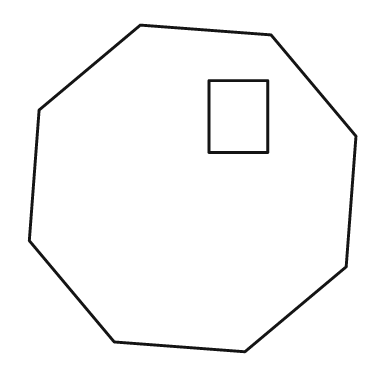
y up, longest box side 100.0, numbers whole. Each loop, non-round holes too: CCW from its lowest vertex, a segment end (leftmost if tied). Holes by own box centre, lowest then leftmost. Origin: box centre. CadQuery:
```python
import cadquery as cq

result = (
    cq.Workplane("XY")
    .moveTo(16.0, -50.0)
    .lineTo(47.0, -24.0)
    .lineTo(50.0, 16.0)
    .lineTo(24.0, 47.0)
    .lineTo(-16.0, 50.0)
    .lineTo(-47.0, 24.0)
    .lineTo(-50.0, -16.0)
    .lineTo(-24.0, -47.0)
    .close()
    .moveTo(5.0, 11.0)
    .lineTo(23.0, 11.0)
    .lineTo(23.0, 33.0)
    .lineTo(5.0, 33.0)
    .close()
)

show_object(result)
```